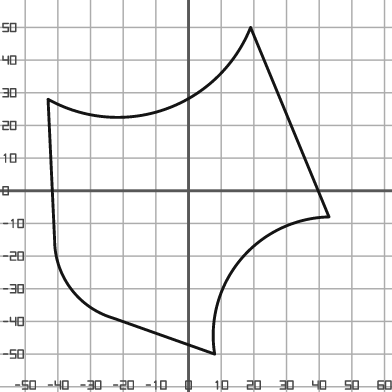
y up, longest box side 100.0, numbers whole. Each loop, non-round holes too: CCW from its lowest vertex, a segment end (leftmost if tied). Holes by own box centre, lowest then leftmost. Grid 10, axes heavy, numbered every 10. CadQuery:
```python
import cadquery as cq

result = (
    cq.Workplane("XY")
    .moveTo(8.0, -50.0)
    .threePointArc((16.0, -21.0), (43.0, -8.0))
    .lineTo(19.0, 50.0)
    .threePointArc((-7.0, 25.0), (-43.0, 28.0))
    .lineTo(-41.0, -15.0)
    .threePointArc((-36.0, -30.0), (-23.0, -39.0))
    .close()
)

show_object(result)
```